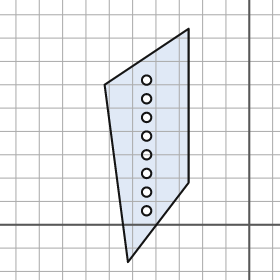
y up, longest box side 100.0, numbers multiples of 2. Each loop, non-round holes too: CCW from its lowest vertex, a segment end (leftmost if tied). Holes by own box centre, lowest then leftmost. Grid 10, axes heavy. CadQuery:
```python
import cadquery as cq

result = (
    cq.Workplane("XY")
    .moveTo(-52.0, -16.0)
    .lineTo(-26.0, 18.0)
    .lineTo(-26.0, 84.0)
    .lineTo(-62.0, 60.0)
    .close()
    .moveTo(-44.0, 6.0)
    .circle(2.0)
    .moveTo(-44.0, 14.0)
    .circle(2.0)
    .moveTo(-44.0, 22.0)
    .circle(2.0)
    .moveTo(-44.0, 30.0)
    .circle(2.0)
    .moveTo(-44.0, 38.0)
    .circle(2.0)
    .moveTo(-44.0, 46.0)
    .circle(2.0)
    .moveTo(-44.0, 54.0)
    .circle(2.0)
    .moveTo(-44.0, 62.0)
    .circle(2.0)
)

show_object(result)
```